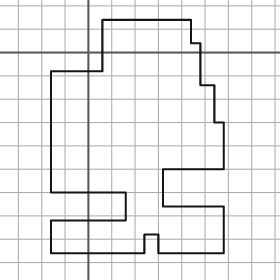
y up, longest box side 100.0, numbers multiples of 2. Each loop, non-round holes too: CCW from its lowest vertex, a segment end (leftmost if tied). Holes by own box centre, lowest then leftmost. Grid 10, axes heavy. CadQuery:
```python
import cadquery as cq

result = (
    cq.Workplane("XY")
    .moveTo(-16.0, -86.0)
    .lineTo(24.0, -86.0)
    .lineTo(24.0, -78.0)
    .lineTo(30.0, -78.0)
    .lineTo(30.0, -86.0)
    .lineTo(58.0, -86.0)
    .lineTo(58.0, -66.0)
    .lineTo(32.0, -66.0)
    .lineTo(32.0, -50.0)
    .lineTo(58.0, -50.0)
    .lineTo(58.0, -30.0)
    .lineTo(54.0, -30.0)
    .lineTo(54.0, -14.0)
    .lineTo(48.0, -14.0)
    .lineTo(48.0, 4.0)
    .lineTo(44.0, 4.0)
    .lineTo(44.0, 14.0)
    .lineTo(6.0, 14.0)
    .lineTo(6.0, -8.0)
    .lineTo(-16.0, -8.0)
    .lineTo(-16.0, -60.0)
    .lineTo(16.0, -60.0)
    .lineTo(16.0, -72.0)
    .lineTo(-16.0, -72.0)
    .close()
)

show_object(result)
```